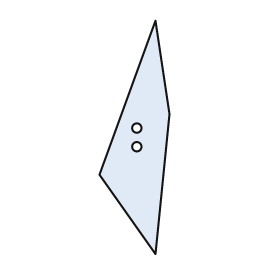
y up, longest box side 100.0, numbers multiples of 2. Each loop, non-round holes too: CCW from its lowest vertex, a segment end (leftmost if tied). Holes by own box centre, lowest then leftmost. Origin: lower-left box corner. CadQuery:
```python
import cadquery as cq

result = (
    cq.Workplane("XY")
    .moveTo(24.0, 0.0)
    .lineTo(30.0, 60.0)
    .lineTo(24.0, 100.0)
    .lineTo(0.0, 34.0)
    .close()
    .moveTo(16.0, 46.0)
    .circle(2.0)
    .moveTo(16.0, 54.0)
    .circle(2.0)
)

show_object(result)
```